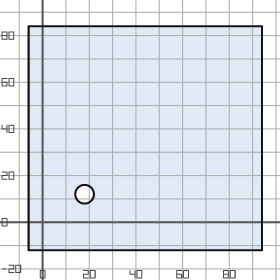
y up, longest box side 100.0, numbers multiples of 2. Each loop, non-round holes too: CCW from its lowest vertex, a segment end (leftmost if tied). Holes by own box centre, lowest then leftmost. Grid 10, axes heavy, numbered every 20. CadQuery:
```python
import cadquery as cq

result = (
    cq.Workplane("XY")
    .moveTo(-6.0, -12.0)
    .lineTo(94.0, -12.0)
    .lineTo(94.0, 84.0)
    .lineTo(-6.0, 84.0)
    .close()
    .moveTo(18.0, 12.0)
    .circle(4.0)
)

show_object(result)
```